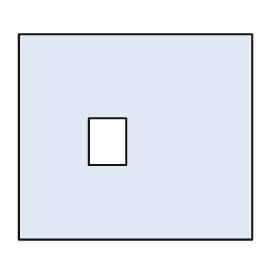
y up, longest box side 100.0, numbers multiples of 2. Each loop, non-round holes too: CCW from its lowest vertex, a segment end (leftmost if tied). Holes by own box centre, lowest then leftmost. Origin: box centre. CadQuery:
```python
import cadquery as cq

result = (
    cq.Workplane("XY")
    .moveTo(-50.0, -44.0)
    .lineTo(50.0, -44.0)
    .lineTo(50.0, 44.0)
    .lineTo(-50.0, 44.0)
    .close()
    .moveTo(-20.0, -12.0)
    .lineTo(-4.0, -12.0)
    .lineTo(-4.0, 8.0)
    .lineTo(-20.0, 8.0)
    .close()
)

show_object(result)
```